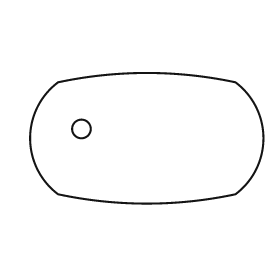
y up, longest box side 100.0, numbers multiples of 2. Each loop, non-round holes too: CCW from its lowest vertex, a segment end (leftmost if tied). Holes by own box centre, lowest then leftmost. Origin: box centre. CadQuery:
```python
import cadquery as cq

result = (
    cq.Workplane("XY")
    .moveTo(-38.0, -24.0)
    .threePointArc((0.0, -28.0), (38.0, -24.0))
    .threePointArc((50.0, 0.0), (38.0, 24.0))
    .threePointArc((0.0, 28.0), (-38.0, 24.0))
    .threePointArc((-50.0, 0.0), (-38.0, -24.0))
    .close()
    .moveTo(-28.0, 4.0)
    .circle(4.0)
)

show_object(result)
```